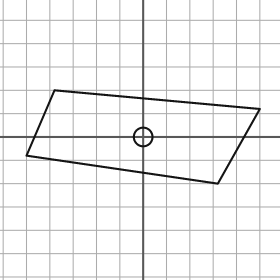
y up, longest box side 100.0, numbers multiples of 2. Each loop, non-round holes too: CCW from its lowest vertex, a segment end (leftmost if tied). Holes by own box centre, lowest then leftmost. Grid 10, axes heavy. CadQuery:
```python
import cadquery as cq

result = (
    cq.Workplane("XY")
    .moveTo(32.0, -20.0)
    .lineTo(50.0, 12.0)
    .lineTo(-38.0, 20.0)
    .lineTo(-50.0, -8.0)
    .close()
    .moveTo(0.0, 0.0)
    .circle(4.0)
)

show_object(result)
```